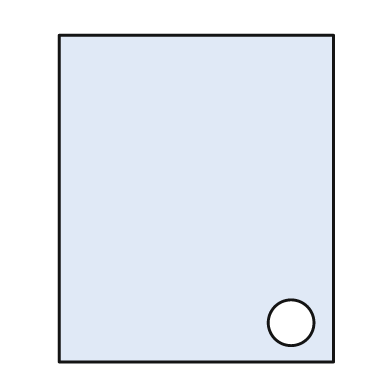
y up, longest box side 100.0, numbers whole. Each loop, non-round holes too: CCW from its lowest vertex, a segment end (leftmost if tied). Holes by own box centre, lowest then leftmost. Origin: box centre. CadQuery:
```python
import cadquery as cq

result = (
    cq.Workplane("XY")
    .moveTo(-42.0, -50.0)
    .lineTo(42.0, -50.0)
    .lineTo(42.0, 50.0)
    .lineTo(-42.0, 50.0)
    .close()
    .moveTo(29.0, -38.0)
    .circle(7.0)
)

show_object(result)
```